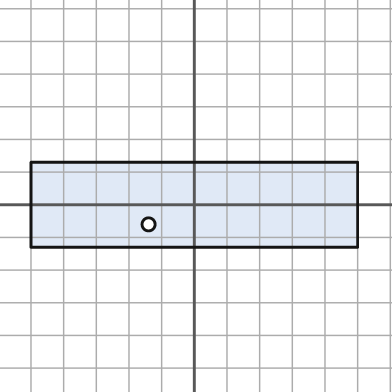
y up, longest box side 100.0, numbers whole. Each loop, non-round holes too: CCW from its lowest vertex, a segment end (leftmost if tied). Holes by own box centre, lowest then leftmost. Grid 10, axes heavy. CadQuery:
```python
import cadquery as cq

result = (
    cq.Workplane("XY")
    .moveTo(-50.0, -13.0)
    .lineTo(50.0, -13.0)
    .lineTo(50.0, 13.0)
    .lineTo(-50.0, 13.0)
    .close()
    .moveTo(-14.0, -6.0)
    .circle(2.0)
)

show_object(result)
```